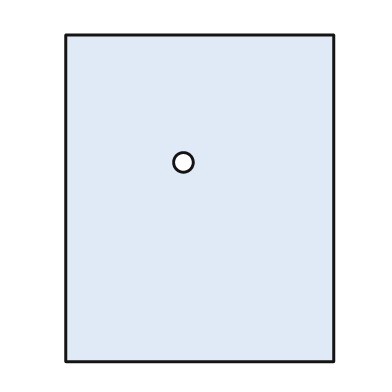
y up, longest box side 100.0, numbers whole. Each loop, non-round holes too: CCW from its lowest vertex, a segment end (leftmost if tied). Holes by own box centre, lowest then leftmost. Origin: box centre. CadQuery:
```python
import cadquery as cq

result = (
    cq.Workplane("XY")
    .moveTo(-41.0, -50.0)
    .lineTo(41.0, -50.0)
    .lineTo(41.0, 50.0)
    .lineTo(-41.0, 50.0)
    .close()
    .moveTo(-5.0, 11.0)
    .circle(3.0)
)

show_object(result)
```